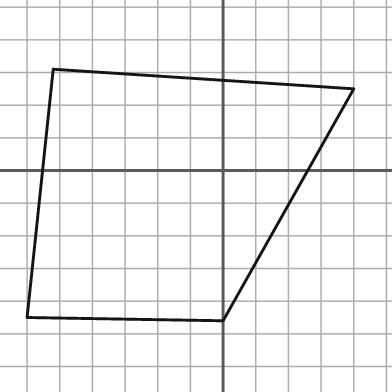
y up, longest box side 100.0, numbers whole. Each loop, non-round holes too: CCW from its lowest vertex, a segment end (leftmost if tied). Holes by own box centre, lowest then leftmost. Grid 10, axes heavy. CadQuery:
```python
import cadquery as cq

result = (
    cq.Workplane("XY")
    .moveTo(0.0, -46.0)
    .lineTo(40.0, 25.0)
    .lineTo(-52.0, 31.0)
    .lineTo(-60.0, -45.0)
    .close()
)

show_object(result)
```